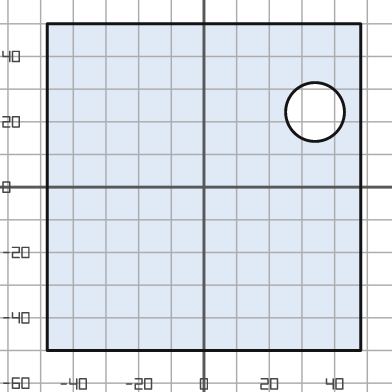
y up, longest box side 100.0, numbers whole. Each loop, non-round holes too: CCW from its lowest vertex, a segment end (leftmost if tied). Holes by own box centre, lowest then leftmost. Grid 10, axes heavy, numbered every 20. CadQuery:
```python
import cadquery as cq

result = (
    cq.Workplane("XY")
    .moveTo(-48.0, -50.0)
    .lineTo(48.0, -50.0)
    .lineTo(48.0, 50.0)
    .lineTo(-48.0, 50.0)
    .close()
    .moveTo(34.0, 23.0)
    .circle(9.0)
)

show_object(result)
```